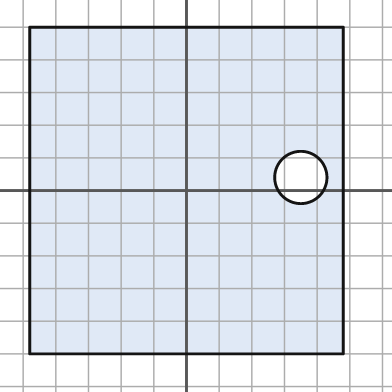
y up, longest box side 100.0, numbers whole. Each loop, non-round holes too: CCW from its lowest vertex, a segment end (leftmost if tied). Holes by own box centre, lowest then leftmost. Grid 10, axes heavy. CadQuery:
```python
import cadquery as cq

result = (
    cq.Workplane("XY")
    .moveTo(-48.0, -50.0)
    .lineTo(48.0, -50.0)
    .lineTo(48.0, 50.0)
    .lineTo(-48.0, 50.0)
    .close()
    .moveTo(35.0, 4.0)
    .circle(8.0)
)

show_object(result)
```